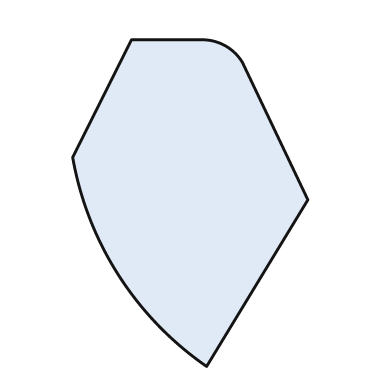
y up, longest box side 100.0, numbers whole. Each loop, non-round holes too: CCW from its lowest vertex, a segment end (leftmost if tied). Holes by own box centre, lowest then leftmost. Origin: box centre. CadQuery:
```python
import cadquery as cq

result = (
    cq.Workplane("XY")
    .moveTo(5.0, -50.0)
    .lineTo(36.0, 1.0)
    .lineTo(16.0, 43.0)
    .threePointArc((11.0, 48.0), (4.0, 50.0))
    .lineTo(-18.0, 50.0)
    .lineTo(-36.0, 14.0)
    .threePointArc((-22.0, -22.0), (5.0, -50.0))
    .close()
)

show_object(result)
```